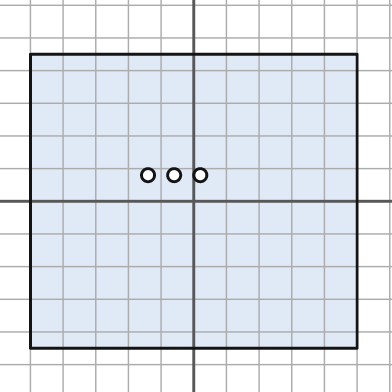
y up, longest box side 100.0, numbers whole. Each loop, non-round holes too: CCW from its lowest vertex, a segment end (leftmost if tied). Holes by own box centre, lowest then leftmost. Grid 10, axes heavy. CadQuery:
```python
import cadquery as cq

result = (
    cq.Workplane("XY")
    .moveTo(-50.0, -45.0)
    .lineTo(50.0, -45.0)
    .lineTo(50.0, 45.0)
    .lineTo(-50.0, 45.0)
    .close()
    .moveTo(-14.0, 8.0)
    .circle(2.0)
    .moveTo(-6.0, 8.0)
    .circle(2.0)
    .moveTo(2.0, 8.0)
    .circle(2.0)
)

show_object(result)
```